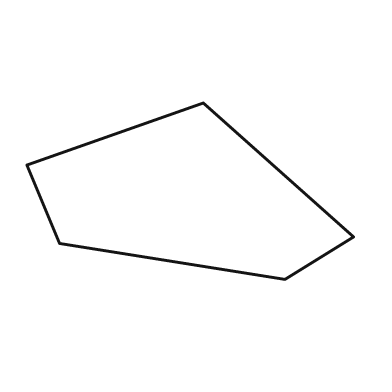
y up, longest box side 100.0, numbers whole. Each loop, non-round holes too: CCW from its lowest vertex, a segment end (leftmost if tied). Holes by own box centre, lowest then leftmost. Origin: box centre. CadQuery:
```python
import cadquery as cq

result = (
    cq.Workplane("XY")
    .moveTo(29.0, -27.0)
    .lineTo(50.0, -14.0)
    .lineTo(4.0, 27.0)
    .lineTo(-50.0, 8.0)
    .lineTo(-40.0, -16.0)
    .close()
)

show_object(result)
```